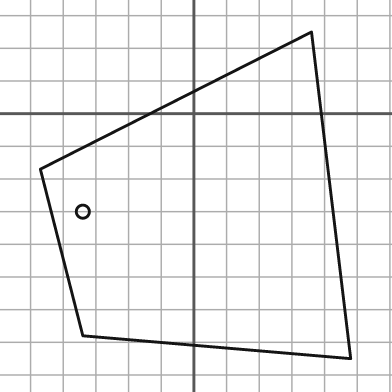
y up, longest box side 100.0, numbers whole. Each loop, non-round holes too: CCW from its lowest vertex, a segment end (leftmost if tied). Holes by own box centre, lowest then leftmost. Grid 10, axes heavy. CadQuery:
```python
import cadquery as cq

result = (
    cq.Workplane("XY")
    .moveTo(48.0, -75.0)
    .lineTo(36.0, 25.0)
    .lineTo(-47.0, -17.0)
    .lineTo(-34.0, -68.0)
    .close()
    .moveTo(-34.0, -30.0)
    .circle(2.0)
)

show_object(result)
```